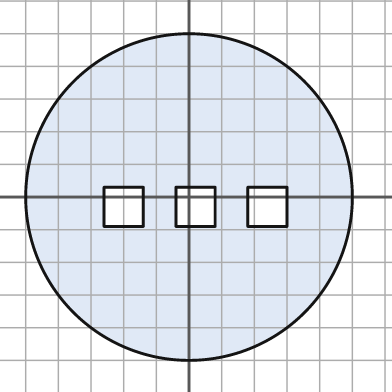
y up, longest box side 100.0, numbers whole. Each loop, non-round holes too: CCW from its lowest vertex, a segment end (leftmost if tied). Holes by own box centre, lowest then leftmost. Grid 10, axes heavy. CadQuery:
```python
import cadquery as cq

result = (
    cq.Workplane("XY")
    .moveTo(0.0, 0.0)
    .circle(50.0)
    .moveTo(-26.0, -9.0)
    .lineTo(-14.0, -9.0)
    .lineTo(-14.0, 3.0)
    .lineTo(-26.0, 3.0)
    .close()
    .moveTo(-4.0, -9.0)
    .lineTo(8.0, -9.0)
    .lineTo(8.0, 3.0)
    .lineTo(-4.0, 3.0)
    .close()
    .moveTo(18.0, -9.0)
    .lineTo(30.0, -9.0)
    .lineTo(30.0, 3.0)
    .lineTo(18.0, 3.0)
    .close()
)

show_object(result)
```